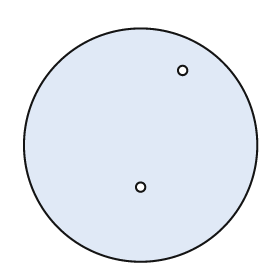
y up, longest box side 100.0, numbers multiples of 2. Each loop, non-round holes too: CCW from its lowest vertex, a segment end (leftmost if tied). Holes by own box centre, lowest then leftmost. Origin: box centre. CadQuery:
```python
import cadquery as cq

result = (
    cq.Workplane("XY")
    .moveTo(0.0, 0.0)
    .circle(50.0)
    .moveTo(0.0, -18.0)
    .circle(2.0)
    .moveTo(18.0, 32.0)
    .circle(2.0)
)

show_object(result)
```